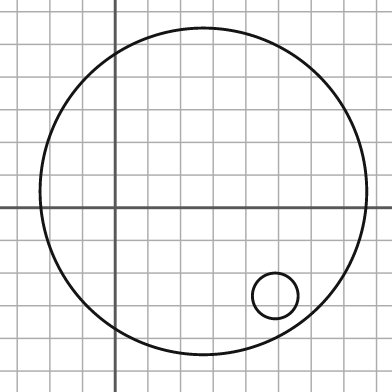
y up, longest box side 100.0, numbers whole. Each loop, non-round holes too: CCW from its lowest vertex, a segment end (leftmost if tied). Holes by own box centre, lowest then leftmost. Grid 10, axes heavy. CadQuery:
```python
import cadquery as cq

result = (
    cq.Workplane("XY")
    .moveTo(27.0, 5.0)
    .circle(50.0)
    .moveTo(49.0, -27.0)
    .circle(7.0)
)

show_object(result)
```